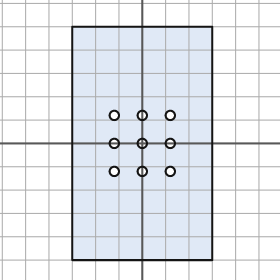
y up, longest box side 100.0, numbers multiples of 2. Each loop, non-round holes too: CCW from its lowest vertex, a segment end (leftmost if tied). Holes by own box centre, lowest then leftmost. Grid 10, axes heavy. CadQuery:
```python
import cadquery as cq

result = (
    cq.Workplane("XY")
    .moveTo(-30.0, -50.0)
    .lineTo(30.0, -50.0)
    .lineTo(30.0, 50.0)
    .lineTo(-30.0, 50.0)
    .close()
    .moveTo(-12.0, -12.0)
    .circle(2.0)
    .moveTo(0.0, -12.0)
    .circle(2.0)
    .moveTo(12.0, -12.0)
    .circle(2.0)
    .moveTo(-12.0, 0.0)
    .circle(2.0)
    .moveTo(0.0, 0.0)
    .circle(2.0)
    .moveTo(12.0, 0.0)
    .circle(2.0)
    .moveTo(-12.0, 12.0)
    .circle(2.0)
    .moveTo(0.0, 12.0)
    .circle(2.0)
    .moveTo(12.0, 12.0)
    .circle(2.0)
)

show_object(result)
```